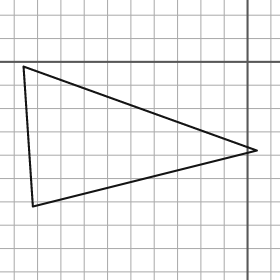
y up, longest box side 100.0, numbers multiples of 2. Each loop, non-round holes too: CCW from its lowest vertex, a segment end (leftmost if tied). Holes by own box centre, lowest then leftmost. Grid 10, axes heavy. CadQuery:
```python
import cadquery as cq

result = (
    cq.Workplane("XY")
    .moveTo(-92.0, -62.0)
    .lineTo(4.0, -38.0)
    .lineTo(-96.0, -2.0)
    .close()
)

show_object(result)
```